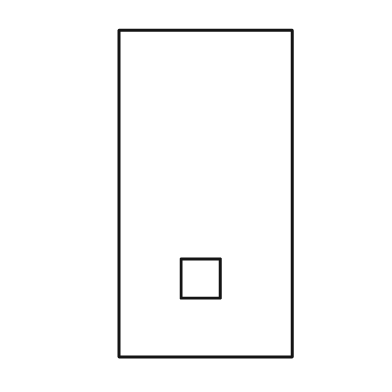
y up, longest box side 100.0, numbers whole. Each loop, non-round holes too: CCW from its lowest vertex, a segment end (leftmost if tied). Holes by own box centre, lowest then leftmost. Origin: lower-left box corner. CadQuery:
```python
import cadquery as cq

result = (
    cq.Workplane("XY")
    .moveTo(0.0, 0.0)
    .lineTo(53.0, 0.0)
    .lineTo(53.0, 100.0)
    .lineTo(0.0, 100.0)
    .close()
    .moveTo(19.0, 18.0)
    .lineTo(31.0, 18.0)
    .lineTo(31.0, 30.0)
    .lineTo(19.0, 30.0)
    .close()
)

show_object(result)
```